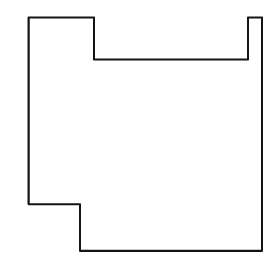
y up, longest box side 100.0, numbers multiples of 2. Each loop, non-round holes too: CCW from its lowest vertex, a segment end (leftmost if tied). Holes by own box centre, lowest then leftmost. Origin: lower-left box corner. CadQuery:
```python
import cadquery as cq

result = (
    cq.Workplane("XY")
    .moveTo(22.0, 0.0)
    .lineTo(100.0, 0.0)
    .lineTo(100.0, 100.0)
    .lineTo(94.0, 100.0)
    .lineTo(94.0, 82.0)
    .lineTo(28.0, 82.0)
    .lineTo(28.0, 100.0)
    .lineTo(0.0, 100.0)
    .lineTo(0.0, 20.0)
    .lineTo(22.0, 20.0)
    .close()
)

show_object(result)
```